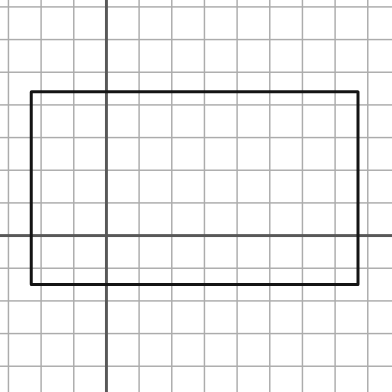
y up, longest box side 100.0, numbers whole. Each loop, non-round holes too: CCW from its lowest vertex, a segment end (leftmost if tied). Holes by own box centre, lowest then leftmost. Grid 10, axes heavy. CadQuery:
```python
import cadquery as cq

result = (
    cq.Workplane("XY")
    .moveTo(-23.0, -15.0)
    .lineTo(77.0, -15.0)
    .lineTo(77.0, 44.0)
    .lineTo(-23.0, 44.0)
    .close()
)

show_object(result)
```